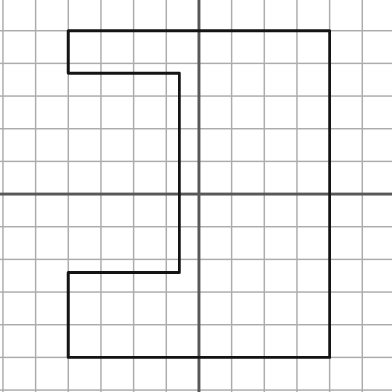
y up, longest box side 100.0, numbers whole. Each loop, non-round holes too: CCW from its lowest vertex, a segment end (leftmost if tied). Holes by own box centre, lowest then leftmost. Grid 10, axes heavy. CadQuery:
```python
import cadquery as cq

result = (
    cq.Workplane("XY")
    .moveTo(-40.0, -50.0)
    .lineTo(40.0, -50.0)
    .lineTo(40.0, 50.0)
    .lineTo(-40.0, 50.0)
    .lineTo(-40.0, 37.0)
    .lineTo(-6.0, 37.0)
    .lineTo(-6.0, -24.0)
    .lineTo(-40.0, -24.0)
    .close()
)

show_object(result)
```